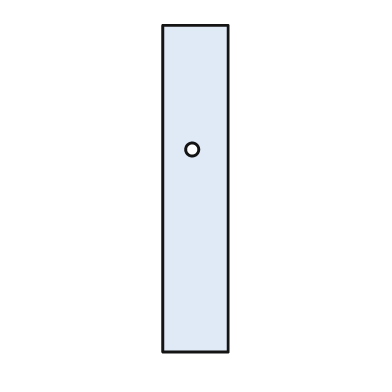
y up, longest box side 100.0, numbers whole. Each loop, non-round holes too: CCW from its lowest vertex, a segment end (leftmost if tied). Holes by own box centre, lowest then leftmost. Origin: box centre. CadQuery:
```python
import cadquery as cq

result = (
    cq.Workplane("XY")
    .moveTo(-10.0, -50.0)
    .lineTo(10.0, -50.0)
    .lineTo(10.0, 50.0)
    .lineTo(-10.0, 50.0)
    .close()
    .moveTo(-1.0, 12.0)
    .circle(2.0)
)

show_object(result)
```